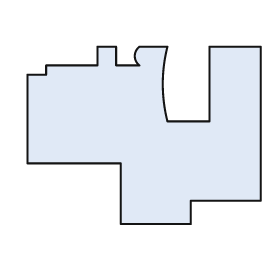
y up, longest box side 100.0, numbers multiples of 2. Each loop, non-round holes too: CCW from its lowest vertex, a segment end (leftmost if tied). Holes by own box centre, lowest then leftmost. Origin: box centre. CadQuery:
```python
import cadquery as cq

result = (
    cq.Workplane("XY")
    .moveTo(-10.0, -38.0)
    .lineTo(20.0, -38.0)
    .lineTo(20.0, -28.0)
    .lineTo(50.0, -28.0)
    .lineTo(50.0, 38.0)
    .lineTo(28.0, 38.0)
    .lineTo(28.0, 6.0)
    .lineTo(10.0, 6.0)
    .threePointArc((8.0, 22.0), (10.0, 38.0))
    .lineTo(-2.0, 38.0)
    .threePointArc((-4.0, 34.0), (-2.0, 30.0))
    .lineTo(-12.0, 30.0)
    .lineTo(-12.0, 38.0)
    .lineTo(-20.0, 38.0)
    .lineTo(-20.0, 30.0)
    .lineTo(-42.0, 30.0)
    .lineTo(-42.0, 26.0)
    .lineTo(-50.0, 26.0)
    .lineTo(-50.0, -12.0)
    .lineTo(-10.0, -12.0)
    .close()
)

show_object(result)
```